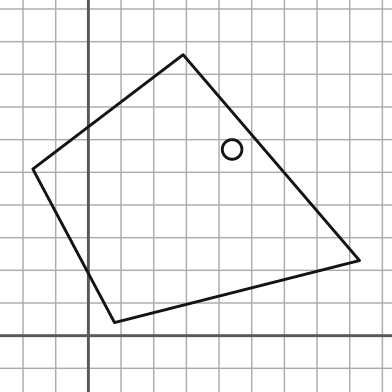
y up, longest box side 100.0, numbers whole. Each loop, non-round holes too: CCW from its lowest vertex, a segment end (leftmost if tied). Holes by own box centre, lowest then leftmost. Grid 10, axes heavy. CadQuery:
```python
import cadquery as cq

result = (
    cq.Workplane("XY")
    .moveTo(8.0, 4.0)
    .lineTo(83.0, 23.0)
    .lineTo(29.0, 86.0)
    .lineTo(-17.0, 51.0)
    .close()
    .moveTo(44.0, 57.0)
    .circle(3.0)
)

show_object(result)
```